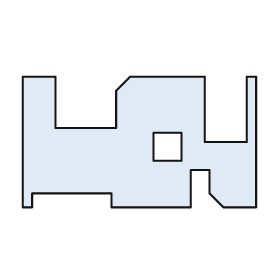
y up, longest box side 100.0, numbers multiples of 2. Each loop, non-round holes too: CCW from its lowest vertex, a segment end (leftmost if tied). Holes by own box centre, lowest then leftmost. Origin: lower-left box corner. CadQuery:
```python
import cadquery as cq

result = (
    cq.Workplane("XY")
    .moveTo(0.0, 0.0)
    .lineTo(4.0, 0.0)
    .lineTo(4.0, 6.0)
    .lineTo(38.0, 6.0)
    .lineTo(38.0, 0.0)
    .lineTo(72.0, 0.0)
    .lineTo(72.0, 16.0)
    .lineTo(80.0, 16.0)
    .lineTo(80.0, 6.0)
    .lineTo(86.0, 0.0)
    .lineTo(100.0, 0.0)
    .lineTo(100.0, 56.0)
    .lineTo(96.0, 56.0)
    .lineTo(96.0, 28.0)
    .lineTo(78.0, 28.0)
    .lineTo(78.0, 56.0)
    .lineTo(46.0, 56.0)
    .lineTo(40.0, 50.0)
    .lineTo(40.0, 34.0)
    .lineTo(14.0, 34.0)
    .lineTo(14.0, 56.0)
    .lineTo(0.0, 56.0)
    .close()
    .moveTo(56.0, 20.0)
    .lineTo(68.0, 20.0)
    .lineTo(68.0, 32.0)
    .lineTo(56.0, 32.0)
    .close()
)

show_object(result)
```